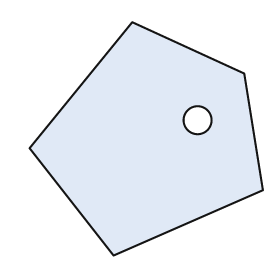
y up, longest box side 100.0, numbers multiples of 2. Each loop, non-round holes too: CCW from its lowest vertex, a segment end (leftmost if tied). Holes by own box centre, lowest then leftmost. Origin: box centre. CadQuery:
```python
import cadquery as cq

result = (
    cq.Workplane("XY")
    .moveTo(-14.0, -50.0)
    .lineTo(50.0, -22.0)
    .lineTo(42.0, 28.0)
    .lineTo(-6.0, 50.0)
    .lineTo(-50.0, -4.0)
    .close()
    .moveTo(22.0, 8.0)
    .circle(6.0)
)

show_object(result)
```